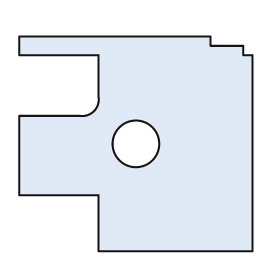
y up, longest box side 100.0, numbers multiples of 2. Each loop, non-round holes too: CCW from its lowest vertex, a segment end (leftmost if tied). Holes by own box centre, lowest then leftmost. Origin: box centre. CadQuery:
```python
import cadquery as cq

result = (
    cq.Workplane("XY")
    .moveTo(-16.0, -46.0)
    .lineTo(50.0, -46.0)
    .lineTo(50.0, 38.0)
    .lineTo(46.0, 38.0)
    .lineTo(46.0, 42.0)
    .lineTo(32.0, 42.0)
    .lineTo(32.0, 46.0)
    .lineTo(-50.0, 46.0)
    .lineTo(-50.0, 38.0)
    .lineTo(-16.0, 38.0)
    .lineTo(-16.0, 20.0)
    .threePointArc((-18.0, 14.0), (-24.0, 12.0))
    .lineTo(-50.0, 12.0)
    .lineTo(-50.0, -22.0)
    .lineTo(-16.0, -22.0)
    .close()
    .moveTo(0.0, 0.0)
    .circle(10.0)
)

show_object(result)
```